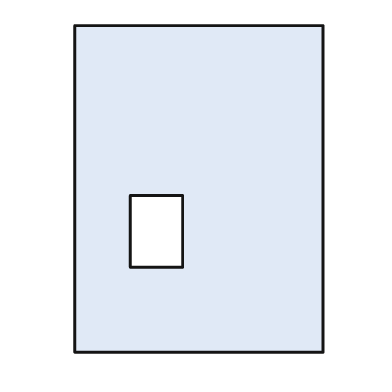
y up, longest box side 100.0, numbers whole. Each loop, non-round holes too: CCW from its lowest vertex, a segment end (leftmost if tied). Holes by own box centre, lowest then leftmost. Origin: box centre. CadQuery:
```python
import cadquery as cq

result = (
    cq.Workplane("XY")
    .moveTo(-38.0, -50.0)
    .lineTo(38.0, -50.0)
    .lineTo(38.0, 50.0)
    .lineTo(-38.0, 50.0)
    .close()
    .moveTo(-21.0, -24.0)
    .lineTo(-5.0, -24.0)
    .lineTo(-5.0, -2.0)
    .lineTo(-21.0, -2.0)
    .close()
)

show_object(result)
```